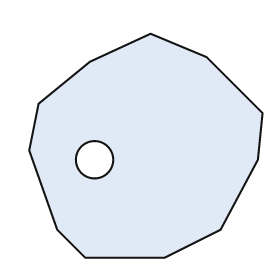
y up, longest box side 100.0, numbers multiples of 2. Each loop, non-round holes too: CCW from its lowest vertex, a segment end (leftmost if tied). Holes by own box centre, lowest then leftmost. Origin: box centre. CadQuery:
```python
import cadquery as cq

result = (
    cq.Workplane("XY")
    .moveTo(-26.0, -48.0)
    .lineTo(8.0, -48.0)
    .lineTo(32.0, -36.0)
    .lineTo(48.0, -6.0)
    .lineTo(50.0, 14.0)
    .lineTo(26.0, 38.0)
    .lineTo(2.0, 48.0)
    .lineTo(-24.0, 36.0)
    .lineTo(-46.0, 18.0)
    .lineTo(-50.0, -2.0)
    .lineTo(-38.0, -36.0)
    .close()
    .moveTo(-22.0, -6.0)
    .circle(8.0)
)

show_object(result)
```